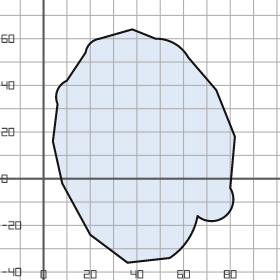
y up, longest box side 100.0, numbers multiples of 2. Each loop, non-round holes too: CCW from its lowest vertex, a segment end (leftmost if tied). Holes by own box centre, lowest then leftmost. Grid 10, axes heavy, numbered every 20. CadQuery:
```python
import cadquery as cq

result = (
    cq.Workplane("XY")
    .moveTo(36.0, -36.0)
    .lineTo(54.0, -34.0)
    .threePointArc((62.0, -26.0), (66.0, -16.0))
    .threePointArc((78.0, -16.0), (80.0, -4.0))
    .lineTo(82.0, 18.0)
    .lineTo(74.0, 38.0)
    .lineTo(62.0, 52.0)
    .threePointArc((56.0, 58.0), (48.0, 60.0))
    .lineTo(38.0, 64.0)
    .lineTo(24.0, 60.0)
    .threePointArc((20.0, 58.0), (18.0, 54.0))
    .lineTo(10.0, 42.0)
    .threePointArc((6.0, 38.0), (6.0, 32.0))
    .lineTo(4.0, 16.0)
    .lineTo(8.0, -2.0)
    .lineTo(20.0, -24.0)
    .close()
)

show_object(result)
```